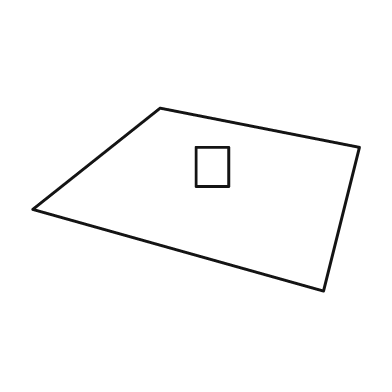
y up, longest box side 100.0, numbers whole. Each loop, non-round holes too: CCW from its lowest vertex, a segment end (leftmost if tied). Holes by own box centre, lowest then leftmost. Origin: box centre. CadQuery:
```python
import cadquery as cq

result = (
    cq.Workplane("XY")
    .moveTo(39.0, -28.0)
    .lineTo(50.0, 16.0)
    .lineTo(-11.0, 28.0)
    .lineTo(-50.0, -3.0)
    .close()
    .moveTo(0.0, 4.0)
    .lineTo(10.0, 4.0)
    .lineTo(10.0, 16.0)
    .lineTo(0.0, 16.0)
    .close()
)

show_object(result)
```